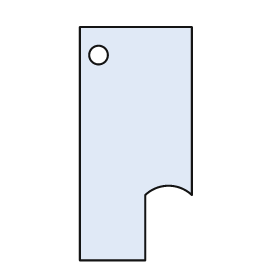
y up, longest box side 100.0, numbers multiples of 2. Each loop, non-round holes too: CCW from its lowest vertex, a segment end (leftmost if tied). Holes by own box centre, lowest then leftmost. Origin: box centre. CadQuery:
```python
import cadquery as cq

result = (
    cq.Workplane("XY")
    .moveTo(-24.0, -50.0)
    .lineTo(4.0, -50.0)
    .lineTo(4.0, -22.0)
    .threePointArc((14.0, -18.0), (24.0, -22.0))
    .lineTo(24.0, 50.0)
    .lineTo(-24.0, 50.0)
    .close()
    .moveTo(-16.0, 38.0)
    .circle(4.0)
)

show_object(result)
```